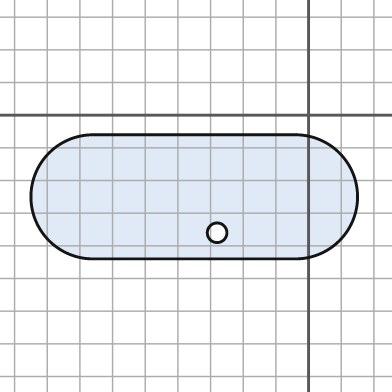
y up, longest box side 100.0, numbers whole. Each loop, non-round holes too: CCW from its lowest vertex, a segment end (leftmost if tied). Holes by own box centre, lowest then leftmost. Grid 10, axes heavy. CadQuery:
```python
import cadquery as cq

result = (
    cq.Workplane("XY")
    .moveTo(-66.0, -44.0)
    .lineTo(-4.0, -44.0)
    .threePointArc((15.0, -25.0), (-4.0, -6.0))
    .lineTo(-66.0, -6.0)
    .threePointArc((-85.0, -25.0), (-66.0, -44.0))
    .close()
    .moveTo(-28.0, -36.0)
    .circle(3.0)
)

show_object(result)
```